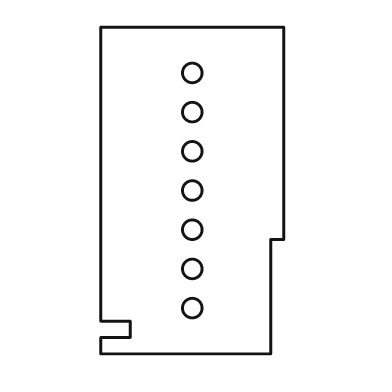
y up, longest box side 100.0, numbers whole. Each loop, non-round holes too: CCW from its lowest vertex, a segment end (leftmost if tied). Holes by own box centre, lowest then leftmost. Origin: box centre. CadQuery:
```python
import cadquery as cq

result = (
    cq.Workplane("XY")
    .moveTo(-28.0, -50.0)
    .lineTo(24.0, -50.0)
    .lineTo(24.0, -15.0)
    .lineTo(28.0, -15.0)
    .lineTo(28.0, 50.0)
    .lineTo(-28.0, 50.0)
    .lineTo(-28.0, -40.0)
    .lineTo(-19.0, -40.0)
    .lineTo(-19.0, -45.0)
    .lineTo(-28.0, -45.0)
    .close()
    .moveTo(0.0, -36.0)
    .circle(3.0)
    .moveTo(0.0, -24.0)
    .circle(3.0)
    .moveTo(0.0, -12.0)
    .circle(3.0)
    .moveTo(0.0, 0.0)
    .circle(3.0)
    .moveTo(0.0, 12.0)
    .circle(3.0)
    .moveTo(0.0, 24.0)
    .circle(3.0)
    .moveTo(0.0, 36.0)
    .circle(3.0)
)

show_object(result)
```